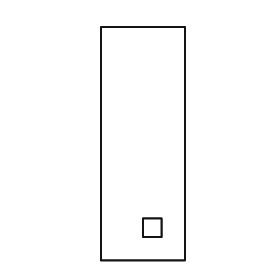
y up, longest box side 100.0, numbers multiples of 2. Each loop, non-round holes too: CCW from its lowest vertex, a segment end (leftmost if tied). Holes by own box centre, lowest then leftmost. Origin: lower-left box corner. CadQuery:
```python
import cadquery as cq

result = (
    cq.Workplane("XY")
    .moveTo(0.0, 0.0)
    .lineTo(36.0, 0.0)
    .lineTo(36.0, 100.0)
    .lineTo(0.0, 100.0)
    .close()
    .moveTo(18.0, 10.0)
    .lineTo(26.0, 10.0)
    .lineTo(26.0, 18.0)
    .lineTo(18.0, 18.0)
    .close()
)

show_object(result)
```